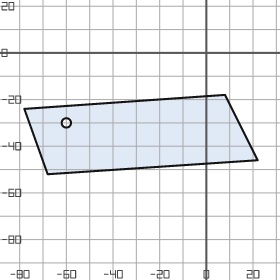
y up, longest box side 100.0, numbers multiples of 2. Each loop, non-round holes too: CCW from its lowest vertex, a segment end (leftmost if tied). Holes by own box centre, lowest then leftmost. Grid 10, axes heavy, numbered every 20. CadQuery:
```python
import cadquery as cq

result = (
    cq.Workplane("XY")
    .moveTo(-68.0, -52.0)
    .lineTo(22.0, -46.0)
    .lineTo(8.0, -18.0)
    .lineTo(-78.0, -24.0)
    .close()
    .moveTo(-60.0, -30.0)
    .circle(2.0)
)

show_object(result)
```